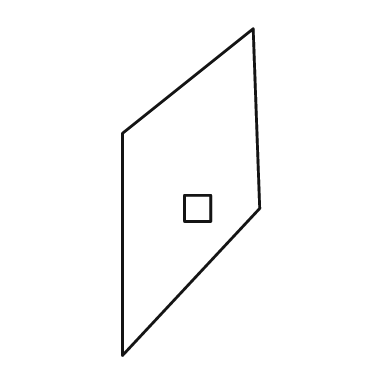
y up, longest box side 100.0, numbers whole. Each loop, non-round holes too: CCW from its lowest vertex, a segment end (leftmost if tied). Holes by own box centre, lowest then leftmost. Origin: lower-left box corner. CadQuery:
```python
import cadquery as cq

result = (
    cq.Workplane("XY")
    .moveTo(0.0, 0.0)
    .lineTo(42.0, 45.0)
    .lineTo(40.0, 100.0)
    .lineTo(0.0, 68.0)
    .close()
    .moveTo(19.0, 41.0)
    .lineTo(27.0, 41.0)
    .lineTo(27.0, 49.0)
    .lineTo(19.0, 49.0)
    .close()
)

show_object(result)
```